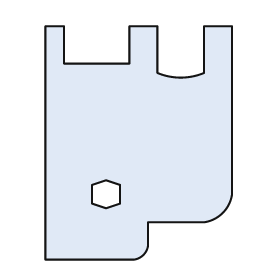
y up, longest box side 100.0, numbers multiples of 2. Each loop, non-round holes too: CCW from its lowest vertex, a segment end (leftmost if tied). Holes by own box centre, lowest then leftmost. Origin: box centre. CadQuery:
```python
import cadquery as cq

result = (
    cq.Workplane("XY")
    .moveTo(-40.0, -50.0)
    .lineTo(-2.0, -50.0)
    .threePointArc((2.0, -48.0), (4.0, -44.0))
    .lineTo(4.0, -34.0)
    .lineTo(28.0, -34.0)
    .threePointArc((36.0, -30.0), (40.0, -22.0))
    .lineTo(40.0, 50.0)
    .lineTo(28.0, 50.0)
    .lineTo(28.0, 30.0)
    .threePointArc((18.0, 28.0), (8.0, 30.0))
    .lineTo(8.0, 50.0)
    .lineTo(-4.0, 50.0)
    .lineTo(-4.0, 34.0)
    .lineTo(-32.0, 34.0)
    .lineTo(-32.0, 50.0)
    .lineTo(-40.0, 50.0)
    .close()
    .moveTo(-14.0, -28.0)
    .lineTo(-8.0, -26.0)
    .lineTo(-8.0, -18.0)
    .lineTo(-14.0, -16.0)
    .lineTo(-20.0, -18.0)
    .lineTo(-20.0, -26.0)
    .close()
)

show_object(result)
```